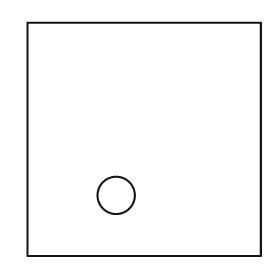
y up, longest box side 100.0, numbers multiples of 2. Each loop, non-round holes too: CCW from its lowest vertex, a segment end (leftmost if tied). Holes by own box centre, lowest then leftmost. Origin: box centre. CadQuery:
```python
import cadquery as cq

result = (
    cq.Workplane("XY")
    .moveTo(-50.0, -50.0)
    .lineTo(50.0, -50.0)
    .lineTo(50.0, 50.0)
    .lineTo(-50.0, 50.0)
    .close()
    .moveTo(-12.0, -24.0)
    .circle(8.0)
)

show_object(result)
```